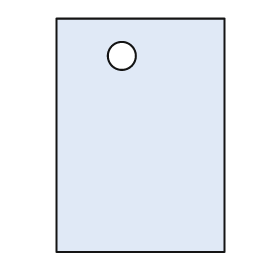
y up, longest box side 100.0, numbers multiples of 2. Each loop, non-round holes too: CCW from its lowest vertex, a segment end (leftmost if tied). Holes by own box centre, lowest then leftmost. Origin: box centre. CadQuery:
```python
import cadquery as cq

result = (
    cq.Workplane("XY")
    .moveTo(-36.0, -50.0)
    .lineTo(36.0, -50.0)
    .lineTo(36.0, 50.0)
    .lineTo(-36.0, 50.0)
    .close()
    .moveTo(-8.0, 34.0)
    .circle(6.0)
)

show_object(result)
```